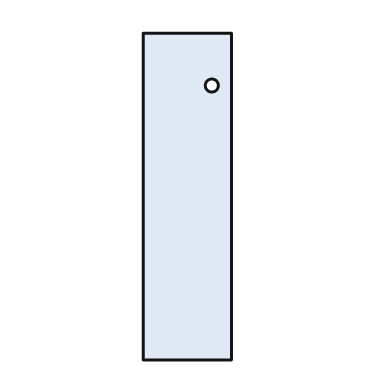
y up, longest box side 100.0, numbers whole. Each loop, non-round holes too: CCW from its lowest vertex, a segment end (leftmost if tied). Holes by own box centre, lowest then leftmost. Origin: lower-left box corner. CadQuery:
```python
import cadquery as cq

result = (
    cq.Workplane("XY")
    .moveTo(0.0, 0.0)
    .lineTo(27.0, 0.0)
    .lineTo(27.0, 100.0)
    .lineTo(0.0, 100.0)
    .close()
    .moveTo(21.0, 84.0)
    .circle(2.0)
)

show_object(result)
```